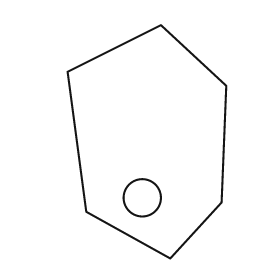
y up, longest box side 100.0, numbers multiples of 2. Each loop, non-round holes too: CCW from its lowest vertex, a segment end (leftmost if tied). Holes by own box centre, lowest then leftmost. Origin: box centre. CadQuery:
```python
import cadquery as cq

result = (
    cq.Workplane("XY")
    .moveTo(10.0, -50.0)
    .lineTo(32.0, -26.0)
    .lineTo(34.0, 24.0)
    .lineTo(6.0, 50.0)
    .lineTo(-34.0, 30.0)
    .lineTo(-26.0, -30.0)
    .close()
    .moveTo(-2.0, -24.0)
    .circle(8.0)
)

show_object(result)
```